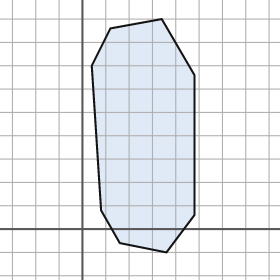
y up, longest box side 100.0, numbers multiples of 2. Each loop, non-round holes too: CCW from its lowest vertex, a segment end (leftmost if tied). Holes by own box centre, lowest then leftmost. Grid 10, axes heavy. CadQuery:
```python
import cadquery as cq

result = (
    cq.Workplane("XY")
    .moveTo(36.0, -10.0)
    .lineTo(48.0, 6.0)
    .lineTo(48.0, 66.0)
    .lineTo(34.0, 90.0)
    .lineTo(12.0, 86.0)
    .lineTo(4.0, 70.0)
    .lineTo(8.0, 8.0)
    .lineTo(16.0, -6.0)
    .close()
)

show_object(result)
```